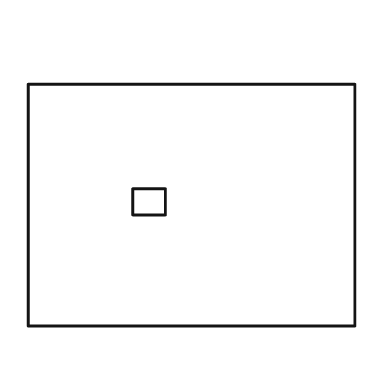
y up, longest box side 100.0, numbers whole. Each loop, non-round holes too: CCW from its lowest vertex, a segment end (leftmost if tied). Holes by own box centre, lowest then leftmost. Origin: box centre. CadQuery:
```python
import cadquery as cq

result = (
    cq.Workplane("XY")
    .moveTo(-50.0, -37.0)
    .lineTo(50.0, -37.0)
    .lineTo(50.0, 37.0)
    .lineTo(-50.0, 37.0)
    .close()
    .moveTo(-18.0, -3.0)
    .lineTo(-8.0, -3.0)
    .lineTo(-8.0, 5.0)
    .lineTo(-18.0, 5.0)
    .close()
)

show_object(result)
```